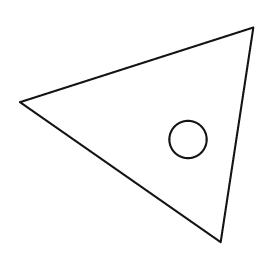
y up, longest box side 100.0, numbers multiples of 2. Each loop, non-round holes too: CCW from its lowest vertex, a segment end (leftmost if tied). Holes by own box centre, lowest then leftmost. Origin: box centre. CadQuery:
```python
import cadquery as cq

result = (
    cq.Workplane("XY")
    .moveTo(36.0, -46.0)
    .lineTo(50.0, 46.0)
    .lineTo(-50.0, 14.0)
    .close()
    .moveTo(22.0, -2.0)
    .circle(8.0)
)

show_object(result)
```